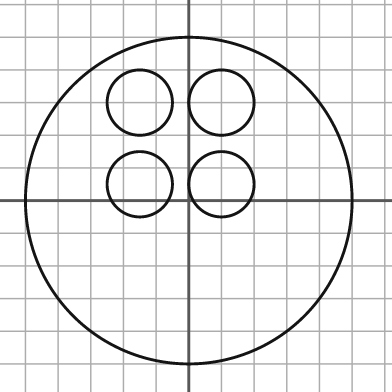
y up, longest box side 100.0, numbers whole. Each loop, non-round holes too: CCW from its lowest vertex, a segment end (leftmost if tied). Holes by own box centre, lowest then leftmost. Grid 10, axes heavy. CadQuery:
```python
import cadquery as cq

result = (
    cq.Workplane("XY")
    .moveTo(0.0, 0.0)
    .circle(50.0)
    .moveTo(-15.0, 5.0)
    .circle(10.0)
    .moveTo(10.0, 5.0)
    .circle(10.0)
    .moveTo(-15.0, 30.0)
    .circle(10.0)
    .moveTo(10.0, 30.0)
    .circle(10.0)
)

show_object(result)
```